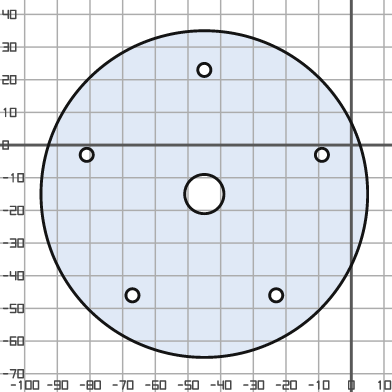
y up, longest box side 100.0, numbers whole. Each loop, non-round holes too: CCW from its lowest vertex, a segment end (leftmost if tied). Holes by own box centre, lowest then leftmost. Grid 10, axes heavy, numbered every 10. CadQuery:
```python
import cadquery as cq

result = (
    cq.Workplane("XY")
    .moveTo(-45.0, -15.0)
    .circle(50.0)
    .moveTo(-67.0, -46.0)
    .circle(2.0)
    .moveTo(-23.0, -46.0)
    .circle(2.0)
    .moveTo(-45.0, -15.0)
    .circle(6.0)
    .moveTo(-81.0, -3.0)
    .circle(2.0)
    .moveTo(-9.0, -3.0)
    .circle(2.0)
    .moveTo(-45.0, 23.0)
    .circle(2.0)
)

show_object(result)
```